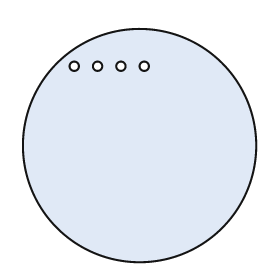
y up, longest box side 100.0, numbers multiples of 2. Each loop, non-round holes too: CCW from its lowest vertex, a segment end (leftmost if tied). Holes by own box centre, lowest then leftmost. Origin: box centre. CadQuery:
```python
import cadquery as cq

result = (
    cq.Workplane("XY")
    .moveTo(0.0, 0.0)
    .circle(50.0)
    .moveTo(-28.0, 34.0)
    .circle(2.0)
    .moveTo(-18.0, 34.0)
    .circle(2.0)
    .moveTo(-8.0, 34.0)
    .circle(2.0)
    .moveTo(2.0, 34.0)
    .circle(2.0)
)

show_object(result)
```